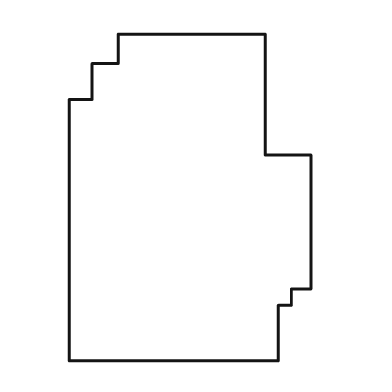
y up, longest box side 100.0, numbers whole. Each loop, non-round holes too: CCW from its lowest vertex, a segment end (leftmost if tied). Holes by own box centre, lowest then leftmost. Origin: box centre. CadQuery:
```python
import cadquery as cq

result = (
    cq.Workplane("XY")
    .moveTo(-37.0, -50.0)
    .lineTo(27.0, -50.0)
    .lineTo(27.0, -33.0)
    .lineTo(31.0, -33.0)
    .lineTo(31.0, -28.0)
    .lineTo(37.0, -28.0)
    .lineTo(37.0, 13.0)
    .lineTo(23.0, 13.0)
    .lineTo(23.0, 50.0)
    .lineTo(-22.0, 50.0)
    .lineTo(-22.0, 41.0)
    .lineTo(-30.0, 41.0)
    .lineTo(-30.0, 30.0)
    .lineTo(-37.0, 30.0)
    .close()
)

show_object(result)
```